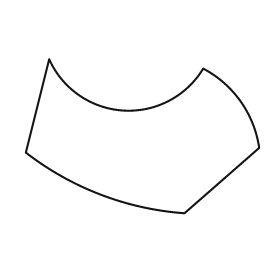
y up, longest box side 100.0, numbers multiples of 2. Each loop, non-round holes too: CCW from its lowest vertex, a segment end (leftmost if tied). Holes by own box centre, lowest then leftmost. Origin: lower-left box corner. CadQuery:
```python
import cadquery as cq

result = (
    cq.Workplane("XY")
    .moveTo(68.0, 0.0)
    .lineTo(100.0, 28.0)
    .threePointArc((92.0, 48.0), (76.0, 62.0))
    .threePointArc((42.0, 44.0), (10.0, 66.0))
    .lineTo(0.0, 26.0)
    .threePointArc((32.0, 8.0), (68.0, 0.0))
    .close()
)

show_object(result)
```